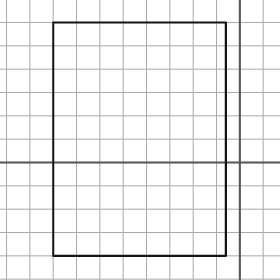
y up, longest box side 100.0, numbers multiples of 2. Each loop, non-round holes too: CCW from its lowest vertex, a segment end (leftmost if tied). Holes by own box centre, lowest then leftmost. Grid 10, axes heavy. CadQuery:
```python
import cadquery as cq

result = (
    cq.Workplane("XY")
    .moveTo(-80.0, -40.0)
    .lineTo(-6.0, -40.0)
    .lineTo(-6.0, 60.0)
    .lineTo(-80.0, 60.0)
    .close()
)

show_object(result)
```